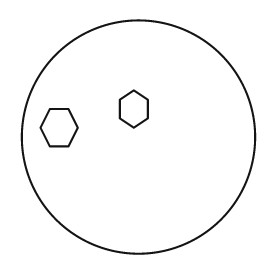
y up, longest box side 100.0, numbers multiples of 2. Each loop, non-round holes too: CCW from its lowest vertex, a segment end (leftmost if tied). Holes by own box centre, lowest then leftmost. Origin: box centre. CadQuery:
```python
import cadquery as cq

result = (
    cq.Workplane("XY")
    .moveTo(0.0, 0.0)
    .circle(50.0)
    .moveTo(-38.0, -4.0)
    .lineTo(-30.0, -4.0)
    .lineTo(-26.0, 4.0)
    .lineTo(-30.0, 12.0)
    .lineTo(-38.0, 12.0)
    .lineTo(-42.0, 4.0)
    .close()
    .moveTo(-2.0, 4.0)
    .lineTo(4.0, 8.0)
    .lineTo(4.0, 16.0)
    .lineTo(-2.0, 20.0)
    .lineTo(-8.0, 16.0)
    .lineTo(-8.0, 8.0)
    .close()
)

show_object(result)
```